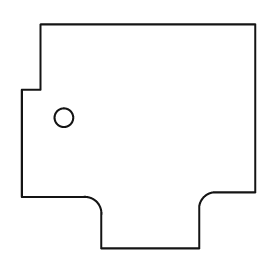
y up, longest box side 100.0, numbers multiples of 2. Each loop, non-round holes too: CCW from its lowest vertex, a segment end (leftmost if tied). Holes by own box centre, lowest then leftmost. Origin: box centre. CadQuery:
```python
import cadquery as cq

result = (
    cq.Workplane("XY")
    .moveTo(-16.0, -48.0)
    .lineTo(26.0, -48.0)
    .lineTo(26.0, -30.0)
    .threePointArc((28.0, -26.0), (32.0, -24.0))
    .lineTo(50.0, -24.0)
    .lineTo(50.0, 48.0)
    .lineTo(-42.0, 48.0)
    .lineTo(-42.0, 20.0)
    .lineTo(-50.0, 20.0)
    .lineTo(-50.0, -26.0)
    .lineTo(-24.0, -26.0)
    .threePointArc((-18.0, -28.0), (-16.0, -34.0))
    .close()
    .moveTo(-32.0, 8.0)
    .circle(4.0)
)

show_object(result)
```